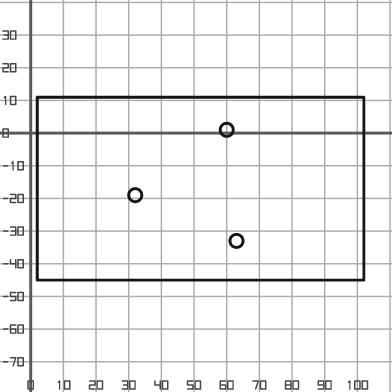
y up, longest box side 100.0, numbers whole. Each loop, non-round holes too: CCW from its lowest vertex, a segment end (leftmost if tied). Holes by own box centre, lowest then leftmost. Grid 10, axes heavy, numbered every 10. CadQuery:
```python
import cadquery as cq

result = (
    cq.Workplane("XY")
    .moveTo(2.0, -45.0)
    .lineTo(102.0, -45.0)
    .lineTo(102.0, 11.0)
    .lineTo(2.0, 11.0)
    .close()
    .moveTo(63.0, -33.0)
    .circle(2.0)
    .moveTo(32.0, -19.0)
    .circle(2.0)
    .moveTo(60.0, 1.0)
    .circle(2.0)
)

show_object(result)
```